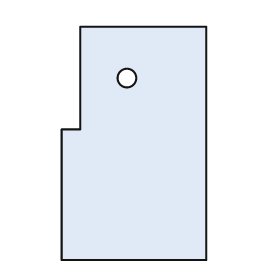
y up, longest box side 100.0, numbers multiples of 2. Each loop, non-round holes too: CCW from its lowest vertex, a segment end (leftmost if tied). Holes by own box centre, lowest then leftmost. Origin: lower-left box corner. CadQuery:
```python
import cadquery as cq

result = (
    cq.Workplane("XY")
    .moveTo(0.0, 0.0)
    .lineTo(62.0, 0.0)
    .lineTo(62.0, 100.0)
    .lineTo(8.0, 100.0)
    .lineTo(8.0, 56.0)
    .lineTo(0.0, 56.0)
    .close()
    .moveTo(28.0, 78.0)
    .circle(4.0)
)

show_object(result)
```